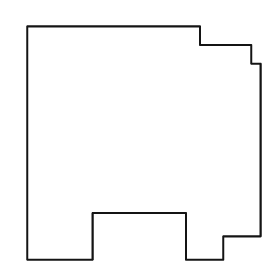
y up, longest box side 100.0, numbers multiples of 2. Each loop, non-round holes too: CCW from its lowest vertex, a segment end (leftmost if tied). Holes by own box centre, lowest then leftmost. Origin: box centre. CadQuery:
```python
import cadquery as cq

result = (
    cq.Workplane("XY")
    .moveTo(-50.0, -50.0)
    .lineTo(-22.0, -50.0)
    .lineTo(-22.0, -30.0)
    .lineTo(18.0, -30.0)
    .lineTo(18.0, -50.0)
    .lineTo(34.0, -50.0)
    .lineTo(34.0, -40.0)
    .lineTo(50.0, -40.0)
    .lineTo(50.0, 34.0)
    .lineTo(46.0, 34.0)
    .lineTo(46.0, 42.0)
    .lineTo(24.0, 42.0)
    .lineTo(24.0, 50.0)
    .lineTo(-50.0, 50.0)
    .close()
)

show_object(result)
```